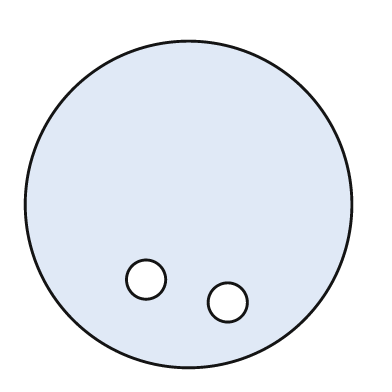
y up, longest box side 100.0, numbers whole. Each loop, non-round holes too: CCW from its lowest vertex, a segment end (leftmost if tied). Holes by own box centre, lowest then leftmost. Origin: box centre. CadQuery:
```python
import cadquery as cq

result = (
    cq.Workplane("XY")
    .moveTo(0.0, 0.0)
    .circle(50.0)
    .moveTo(12.0, -30.0)
    .circle(6.0)
    .moveTo(-13.0, -23.0)
    .circle(6.0)
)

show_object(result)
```